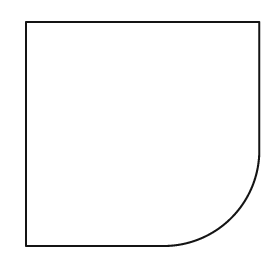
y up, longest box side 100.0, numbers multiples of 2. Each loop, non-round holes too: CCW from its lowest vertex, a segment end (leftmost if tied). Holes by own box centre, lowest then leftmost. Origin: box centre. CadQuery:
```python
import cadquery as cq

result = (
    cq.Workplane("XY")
    .moveTo(-50.0, -48.0)
    .lineTo(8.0, -48.0)
    .threePointArc((38.0, -36.0), (50.0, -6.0))
    .lineTo(50.0, 48.0)
    .lineTo(-50.0, 48.0)
    .close()
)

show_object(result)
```